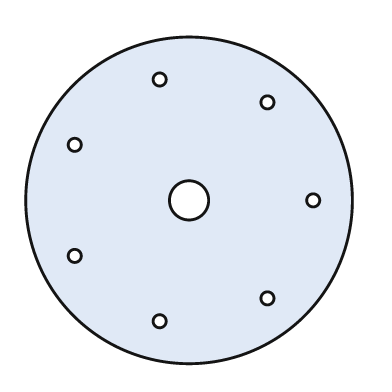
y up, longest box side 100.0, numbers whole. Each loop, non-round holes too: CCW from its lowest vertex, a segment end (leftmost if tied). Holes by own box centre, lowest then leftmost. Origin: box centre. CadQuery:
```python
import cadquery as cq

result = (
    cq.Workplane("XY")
    .moveTo(0.0, 0.0)
    .circle(50.0)
    .moveTo(-9.0, -37.0)
    .circle(2.0)
    .moveTo(24.0, -30.0)
    .circle(2.0)
    .moveTo(-35.0, -17.0)
    .circle(2.0)
    .moveTo(0.0, 0.0)
    .circle(6.0)
    .moveTo(38.0, 0.0)
    .circle(2.0)
    .moveTo(-35.0, 17.0)
    .circle(2.0)
    .moveTo(24.0, 30.0)
    .circle(2.0)
    .moveTo(-9.0, 37.0)
    .circle(2.0)
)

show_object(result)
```